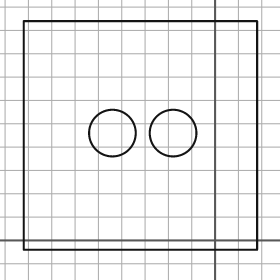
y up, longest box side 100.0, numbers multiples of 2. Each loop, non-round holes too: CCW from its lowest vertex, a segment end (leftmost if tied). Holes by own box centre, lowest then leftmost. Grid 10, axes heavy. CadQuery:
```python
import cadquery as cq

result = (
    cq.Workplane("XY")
    .moveTo(-82.0, -4.0)
    .lineTo(18.0, -4.0)
    .lineTo(18.0, 94.0)
    .lineTo(-82.0, 94.0)
    .close()
    .moveTo(-44.0, 46.0)
    .circle(10.0)
    .moveTo(-18.0, 46.0)
    .circle(10.0)
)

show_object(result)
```